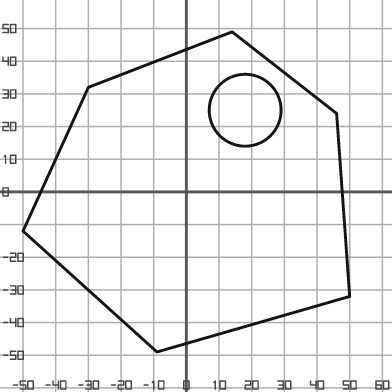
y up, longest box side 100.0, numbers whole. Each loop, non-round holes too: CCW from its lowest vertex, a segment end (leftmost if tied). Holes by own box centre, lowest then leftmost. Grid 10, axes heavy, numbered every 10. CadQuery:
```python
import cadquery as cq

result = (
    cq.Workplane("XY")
    .moveTo(-9.0, -49.0)
    .lineTo(50.0, -32.0)
    .lineTo(46.0, 24.0)
    .lineTo(14.0, 49.0)
    .lineTo(-30.0, 32.0)
    .lineTo(-50.0, -12.0)
    .close()
    .moveTo(18.0, 25.0)
    .circle(11.0)
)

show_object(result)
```